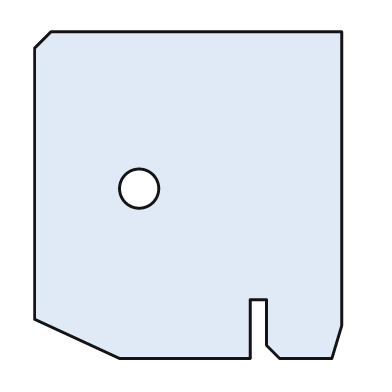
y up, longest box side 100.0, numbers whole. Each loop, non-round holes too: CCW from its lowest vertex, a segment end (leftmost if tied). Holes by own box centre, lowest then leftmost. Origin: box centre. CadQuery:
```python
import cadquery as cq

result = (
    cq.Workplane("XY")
    .moveTo(-21.0, -50.0)
    .lineTo(19.0, -50.0)
    .lineTo(19.0, -32.0)
    .lineTo(24.0, -32.0)
    .lineTo(24.0, -46.0)
    .lineTo(28.0, -50.0)
    .lineTo(44.0, -50.0)
    .lineTo(47.0, -40.0)
    .lineTo(47.0, 50.0)
    .lineTo(-42.0, 50.0)
    .lineTo(-47.0, 45.0)
    .lineTo(-47.0, -38.0)
    .close()
    .moveTo(-15.0, 2.0)
    .circle(6.0)
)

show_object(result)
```